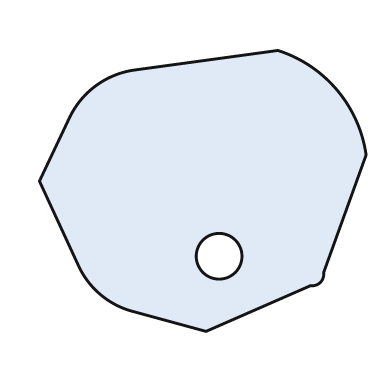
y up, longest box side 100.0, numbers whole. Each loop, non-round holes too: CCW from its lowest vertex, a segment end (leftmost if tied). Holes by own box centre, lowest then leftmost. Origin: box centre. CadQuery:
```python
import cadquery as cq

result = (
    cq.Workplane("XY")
    .moveTo(1.0, -43.0)
    .lineTo(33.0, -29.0)
    .threePointArc((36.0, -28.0), (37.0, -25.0))
    .lineTo(50.0, 11.0)
    .threePointArc((41.0, 31.0), (23.0, 43.0))
    .lineTo(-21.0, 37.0)
    .threePointArc((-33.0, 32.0), (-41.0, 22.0))
    .lineTo(-50.0, 3.0)
    .lineTo(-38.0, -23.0)
    .threePointArc((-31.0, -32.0), (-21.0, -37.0))
    .close()
    .moveTo(5.0, -20.0)
    .circle(7.0)
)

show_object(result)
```